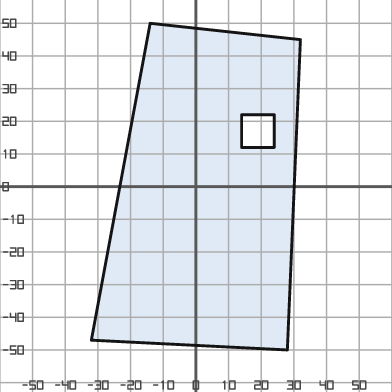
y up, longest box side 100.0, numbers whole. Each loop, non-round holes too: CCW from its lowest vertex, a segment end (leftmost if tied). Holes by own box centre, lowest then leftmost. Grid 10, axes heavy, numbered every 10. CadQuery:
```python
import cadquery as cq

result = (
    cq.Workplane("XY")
    .moveTo(28.0, -50.0)
    .lineTo(32.0, 45.0)
    .lineTo(-14.0, 50.0)
    .lineTo(-32.0, -47.0)
    .close()
    .moveTo(14.0, 12.0)
    .lineTo(24.0, 12.0)
    .lineTo(24.0, 22.0)
    .lineTo(14.0, 22.0)
    .close()
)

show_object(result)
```